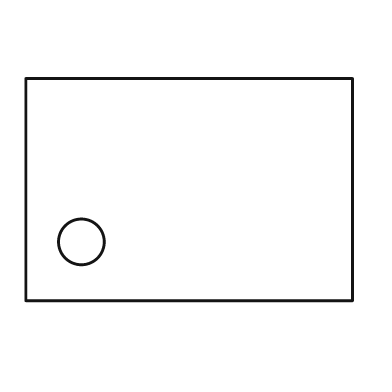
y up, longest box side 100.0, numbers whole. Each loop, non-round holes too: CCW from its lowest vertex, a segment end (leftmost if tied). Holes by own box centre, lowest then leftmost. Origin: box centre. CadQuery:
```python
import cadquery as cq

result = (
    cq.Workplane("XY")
    .moveTo(-50.0, -34.0)
    .lineTo(50.0, -34.0)
    .lineTo(50.0, 34.0)
    .lineTo(-50.0, 34.0)
    .close()
    .moveTo(-33.0, -16.0)
    .circle(7.0)
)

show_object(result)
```